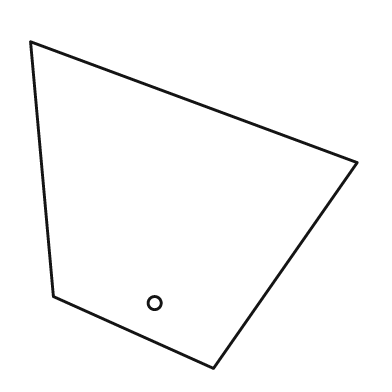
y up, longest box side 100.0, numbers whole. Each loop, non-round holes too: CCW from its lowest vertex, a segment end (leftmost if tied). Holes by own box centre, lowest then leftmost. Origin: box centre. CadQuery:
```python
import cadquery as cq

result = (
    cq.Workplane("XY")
    .moveTo(6.0, -50.0)
    .lineTo(50.0, 13.0)
    .lineTo(-50.0, 50.0)
    .lineTo(-43.0, -28.0)
    .close()
    .moveTo(-12.0, -30.0)
    .circle(2.0)
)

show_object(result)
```